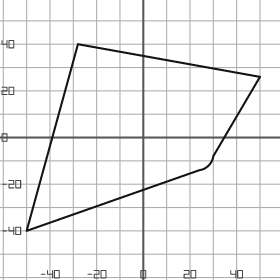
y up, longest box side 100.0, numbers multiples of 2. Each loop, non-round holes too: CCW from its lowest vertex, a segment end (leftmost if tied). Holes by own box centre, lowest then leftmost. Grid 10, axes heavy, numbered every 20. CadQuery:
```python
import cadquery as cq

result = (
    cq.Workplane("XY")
    .moveTo(-50.0, -40.0)
    .lineTo(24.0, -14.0)
    .threePointArc((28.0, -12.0), (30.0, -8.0))
    .lineTo(50.0, 26.0)
    .lineTo(-28.0, 40.0)
    .close()
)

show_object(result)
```